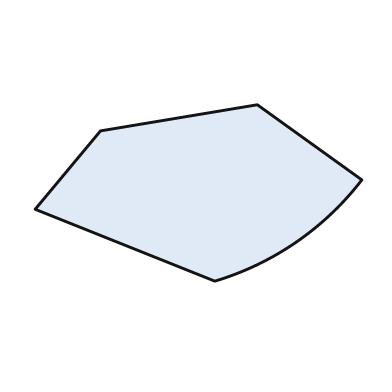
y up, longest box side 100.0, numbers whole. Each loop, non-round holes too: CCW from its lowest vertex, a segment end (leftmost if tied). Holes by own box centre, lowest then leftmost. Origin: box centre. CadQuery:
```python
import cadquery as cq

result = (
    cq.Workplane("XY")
    .moveTo(5.0, -27.0)
    .threePointArc((30.0, -15.0), (50.0, 4.0))
    .lineTo(18.0, 27.0)
    .lineTo(-30.0, 19.0)
    .lineTo(-50.0, -5.0)
    .close()
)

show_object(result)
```